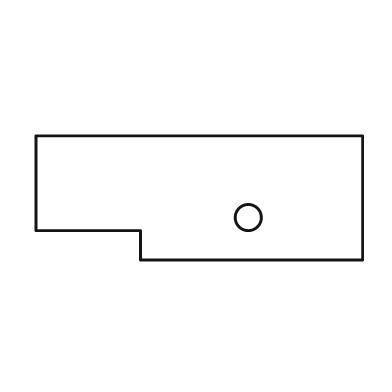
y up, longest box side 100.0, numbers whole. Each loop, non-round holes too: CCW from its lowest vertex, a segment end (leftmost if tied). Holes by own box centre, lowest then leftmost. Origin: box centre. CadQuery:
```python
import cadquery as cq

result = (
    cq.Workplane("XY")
    .moveTo(-18.0, -19.0)
    .lineTo(50.0, -19.0)
    .lineTo(50.0, 19.0)
    .lineTo(-50.0, 19.0)
    .lineTo(-50.0, -10.0)
    .lineTo(-18.0, -10.0)
    .close()
    .moveTo(15.0, -6.0)
    .circle(4.0)
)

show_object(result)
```